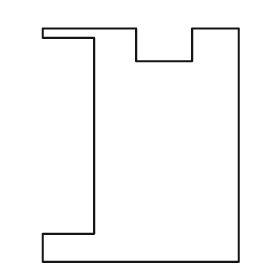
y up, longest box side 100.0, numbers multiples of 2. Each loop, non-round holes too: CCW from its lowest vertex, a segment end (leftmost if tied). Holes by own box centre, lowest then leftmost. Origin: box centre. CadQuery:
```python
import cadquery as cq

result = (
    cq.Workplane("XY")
    .moveTo(-42.0, -50.0)
    .lineTo(42.0, -50.0)
    .lineTo(42.0, 50.0)
    .lineTo(22.0, 50.0)
    .lineTo(22.0, 36.0)
    .lineTo(-2.0, 36.0)
    .lineTo(-2.0, 50.0)
    .lineTo(-42.0, 50.0)
    .lineTo(-42.0, 46.0)
    .lineTo(-20.0, 46.0)
    .lineTo(-20.0, -38.0)
    .lineTo(-42.0, -38.0)
    .close()
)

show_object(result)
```